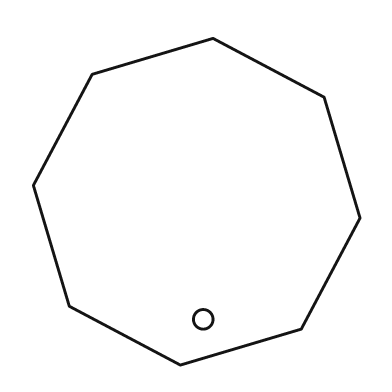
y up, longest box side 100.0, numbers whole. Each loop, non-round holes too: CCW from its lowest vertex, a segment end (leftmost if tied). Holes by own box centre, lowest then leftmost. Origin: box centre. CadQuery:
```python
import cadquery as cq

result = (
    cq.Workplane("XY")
    .moveTo(-5.0, -50.0)
    .lineTo(32.0, -39.0)
    .lineTo(50.0, -5.0)
    .lineTo(39.0, 32.0)
    .lineTo(5.0, 50.0)
    .lineTo(-32.0, 39.0)
    .lineTo(-50.0, 5.0)
    .lineTo(-39.0, -32.0)
    .close()
    .moveTo(2.0, -36.0)
    .circle(3.0)
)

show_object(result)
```